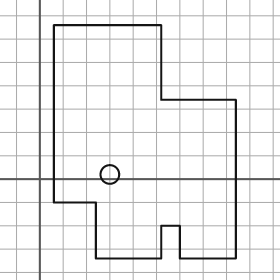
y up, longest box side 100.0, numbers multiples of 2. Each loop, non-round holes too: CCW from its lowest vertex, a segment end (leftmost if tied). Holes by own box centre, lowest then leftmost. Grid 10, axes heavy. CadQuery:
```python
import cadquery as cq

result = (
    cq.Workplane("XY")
    .moveTo(24.0, -34.0)
    .lineTo(52.0, -34.0)
    .lineTo(52.0, -20.0)
    .lineTo(60.0, -20.0)
    .lineTo(60.0, -34.0)
    .lineTo(84.0, -34.0)
    .lineTo(84.0, 34.0)
    .lineTo(52.0, 34.0)
    .lineTo(52.0, 66.0)
    .lineTo(6.0, 66.0)
    .lineTo(6.0, -10.0)
    .lineTo(24.0, -10.0)
    .close()
    .moveTo(30.0, 2.0)
    .circle(4.0)
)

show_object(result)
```